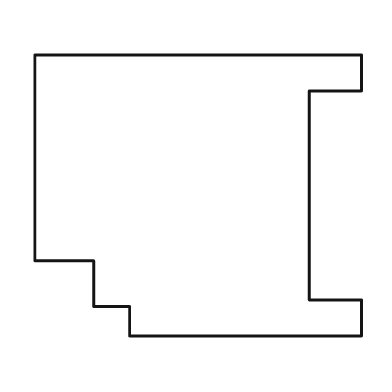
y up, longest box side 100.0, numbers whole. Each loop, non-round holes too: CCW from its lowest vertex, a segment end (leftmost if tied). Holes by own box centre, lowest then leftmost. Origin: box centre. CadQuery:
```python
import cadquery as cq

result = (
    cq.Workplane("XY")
    .moveTo(-21.0, -43.0)
    .lineTo(50.0, -43.0)
    .lineTo(50.0, -32.0)
    .lineTo(34.0, -32.0)
    .lineTo(34.0, 32.0)
    .lineTo(50.0, 32.0)
    .lineTo(50.0, 43.0)
    .lineTo(-50.0, 43.0)
    .lineTo(-50.0, -20.0)
    .lineTo(-32.0, -20.0)
    .lineTo(-32.0, -34.0)
    .lineTo(-21.0, -34.0)
    .close()
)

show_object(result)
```